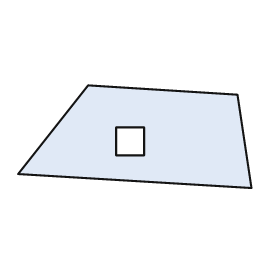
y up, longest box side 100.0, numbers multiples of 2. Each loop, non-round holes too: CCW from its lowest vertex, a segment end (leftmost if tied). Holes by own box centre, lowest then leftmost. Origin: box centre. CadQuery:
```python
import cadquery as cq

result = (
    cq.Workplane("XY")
    .moveTo(50.0, -22.0)
    .lineTo(44.0, 18.0)
    .lineTo(-20.0, 22.0)
    .lineTo(-50.0, -16.0)
    .close()
    .moveTo(-8.0, -8.0)
    .lineTo(4.0, -8.0)
    .lineTo(4.0, 4.0)
    .lineTo(-8.0, 4.0)
    .close()
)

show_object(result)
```